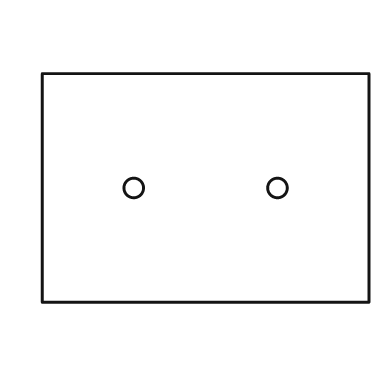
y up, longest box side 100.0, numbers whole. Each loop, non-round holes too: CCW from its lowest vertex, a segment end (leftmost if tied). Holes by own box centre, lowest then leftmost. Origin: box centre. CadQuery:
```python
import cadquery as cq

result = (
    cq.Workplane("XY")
    .moveTo(-50.0, -35.0)
    .lineTo(50.0, -35.0)
    .lineTo(50.0, 35.0)
    .lineTo(-50.0, 35.0)
    .close()
    .moveTo(-22.0, 0.0)
    .circle(3.0)
    .moveTo(22.0, 0.0)
    .circle(3.0)
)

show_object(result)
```